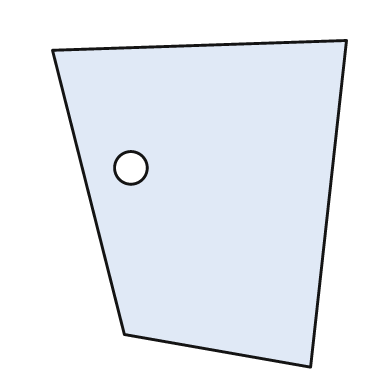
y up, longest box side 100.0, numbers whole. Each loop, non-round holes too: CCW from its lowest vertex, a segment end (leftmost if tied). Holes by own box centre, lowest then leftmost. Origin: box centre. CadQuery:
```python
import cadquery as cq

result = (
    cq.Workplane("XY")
    .moveTo(34.0, -50.0)
    .lineTo(45.0, 50.0)
    .lineTo(-45.0, 47.0)
    .lineTo(-23.0, -40.0)
    .close()
    .moveTo(-21.0, 11.0)
    .circle(5.0)
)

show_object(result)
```